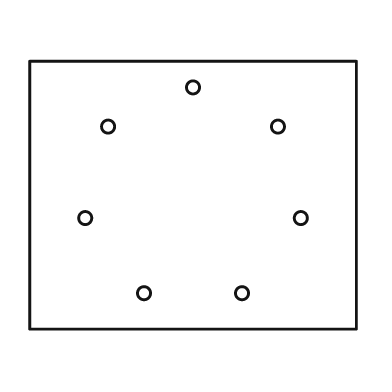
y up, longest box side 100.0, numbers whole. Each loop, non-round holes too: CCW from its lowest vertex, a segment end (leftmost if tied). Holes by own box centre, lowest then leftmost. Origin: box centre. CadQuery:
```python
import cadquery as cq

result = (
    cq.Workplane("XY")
    .moveTo(-50.0, -41.0)
    .lineTo(50.0, -41.0)
    .lineTo(50.0, 41.0)
    .lineTo(-50.0, 41.0)
    .close()
    .moveTo(-15.0, -30.0)
    .circle(2.0)
    .moveTo(15.0, -30.0)
    .circle(2.0)
    .moveTo(-33.0, -7.0)
    .circle(2.0)
    .moveTo(33.0, -7.0)
    .circle(2.0)
    .moveTo(-26.0, 21.0)
    .circle(2.0)
    .moveTo(26.0, 21.0)
    .circle(2.0)
    .moveTo(0.0, 33.0)
    .circle(2.0)
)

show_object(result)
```